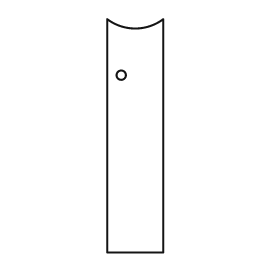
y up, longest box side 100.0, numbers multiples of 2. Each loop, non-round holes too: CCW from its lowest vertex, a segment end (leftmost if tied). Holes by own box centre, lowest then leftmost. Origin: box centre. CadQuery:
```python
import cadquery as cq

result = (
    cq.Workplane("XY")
    .moveTo(-12.0, -50.0)
    .lineTo(12.0, -50.0)
    .lineTo(12.0, 50.0)
    .threePointArc((0.0, 46.0), (-12.0, 50.0))
    .close()
    .moveTo(-6.0, 26.0)
    .circle(2.0)
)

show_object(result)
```